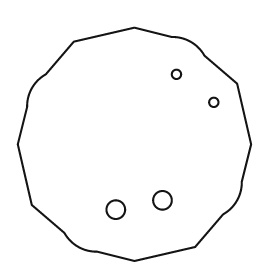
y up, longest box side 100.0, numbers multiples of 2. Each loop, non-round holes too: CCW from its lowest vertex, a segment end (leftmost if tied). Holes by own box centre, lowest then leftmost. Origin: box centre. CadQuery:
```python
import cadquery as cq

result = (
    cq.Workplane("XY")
    .moveTo(0.0, -50.0)
    .lineTo(26.0, -44.0)
    .lineTo(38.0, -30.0)
    .threePointArc((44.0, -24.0), (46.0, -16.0))
    .lineTo(50.0, 0.0)
    .lineTo(44.0, 26.0)
    .lineTo(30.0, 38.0)
    .threePointArc((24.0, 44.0), (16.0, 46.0))
    .lineTo(0.0, 50.0)
    .lineTo(-26.0, 44.0)
    .lineTo(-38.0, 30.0)
    .threePointArc((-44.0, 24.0), (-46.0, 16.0))
    .lineTo(-50.0, 0.0)
    .lineTo(-44.0, -26.0)
    .lineTo(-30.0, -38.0)
    .threePointArc((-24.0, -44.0), (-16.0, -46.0))
    .close()
    .moveTo(-8.0, -28.0)
    .circle(4.0)
    .moveTo(12.0, -24.0)
    .circle(4.0)
    .moveTo(34.0, 18.0)
    .circle(2.0)
    .moveTo(18.0, 30.0)
    .circle(2.0)
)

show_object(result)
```